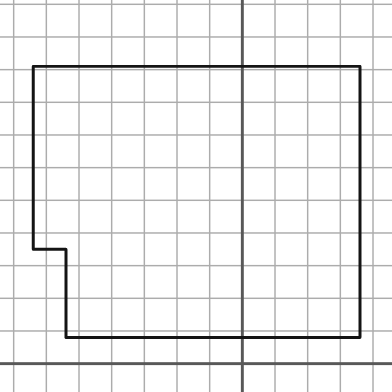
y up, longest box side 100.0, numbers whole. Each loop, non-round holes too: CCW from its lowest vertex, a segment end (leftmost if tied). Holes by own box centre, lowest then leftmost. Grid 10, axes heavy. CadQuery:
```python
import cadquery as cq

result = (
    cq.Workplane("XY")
    .moveTo(-54.0, 8.0)
    .lineTo(36.0, 8.0)
    .lineTo(36.0, 91.0)
    .lineTo(-64.0, 91.0)
    .lineTo(-64.0, 35.0)
    .lineTo(-54.0, 35.0)
    .close()
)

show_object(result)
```